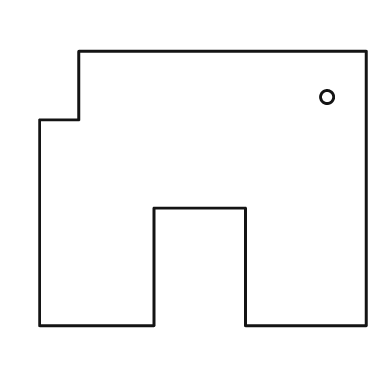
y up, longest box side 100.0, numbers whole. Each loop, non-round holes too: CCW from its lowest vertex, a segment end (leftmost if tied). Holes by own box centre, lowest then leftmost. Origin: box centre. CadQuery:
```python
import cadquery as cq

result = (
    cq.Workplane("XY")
    .moveTo(-50.0, -42.0)
    .lineTo(-15.0, -42.0)
    .lineTo(-15.0, -6.0)
    .lineTo(13.0, -6.0)
    .lineTo(13.0, -42.0)
    .lineTo(50.0, -42.0)
    .lineTo(50.0, 42.0)
    .lineTo(-38.0, 42.0)
    .lineTo(-38.0, 21.0)
    .lineTo(-50.0, 21.0)
    .close()
    .moveTo(38.0, 28.0)
    .circle(2.0)
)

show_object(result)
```